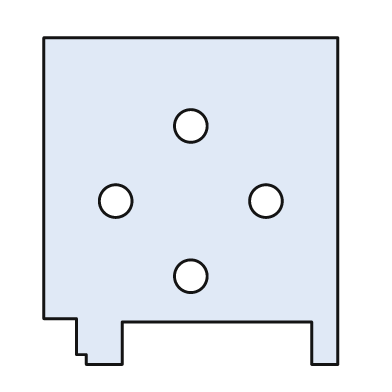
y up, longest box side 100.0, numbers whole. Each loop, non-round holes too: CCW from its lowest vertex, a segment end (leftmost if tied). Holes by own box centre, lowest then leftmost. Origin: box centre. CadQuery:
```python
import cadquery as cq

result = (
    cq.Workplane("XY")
    .moveTo(-32.0, -50.0)
    .lineTo(-21.0, -50.0)
    .lineTo(-21.0, -37.0)
    .lineTo(37.0, -37.0)
    .lineTo(37.0, -50.0)
    .lineTo(45.0, -50.0)
    .lineTo(45.0, 50.0)
    .lineTo(-45.0, 50.0)
    .lineTo(-45.0, -36.0)
    .lineTo(-35.0, -36.0)
    .lineTo(-35.0, -47.0)
    .lineTo(-32.0, -47.0)
    .close()
    .moveTo(0.0, -23.0)
    .circle(5.0)
    .moveTo(-23.0, 0.0)
    .circle(5.0)
    .moveTo(23.0, 0.0)
    .circle(5.0)
    .moveTo(0.0, 23.0)
    .circle(5.0)
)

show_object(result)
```